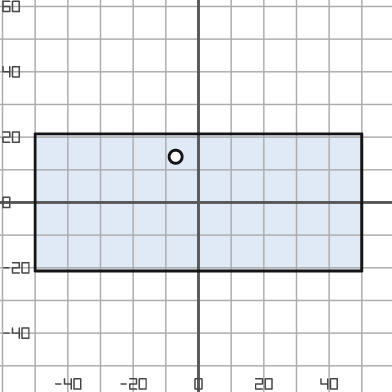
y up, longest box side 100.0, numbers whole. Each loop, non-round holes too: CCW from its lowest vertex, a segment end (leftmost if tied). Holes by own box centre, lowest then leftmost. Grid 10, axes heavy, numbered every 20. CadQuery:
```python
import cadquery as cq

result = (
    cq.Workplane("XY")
    .moveTo(-50.0, -21.0)
    .lineTo(50.0, -21.0)
    .lineTo(50.0, 21.0)
    .lineTo(-50.0, 21.0)
    .close()
    .moveTo(-7.0, 14.0)
    .circle(2.0)
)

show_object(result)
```